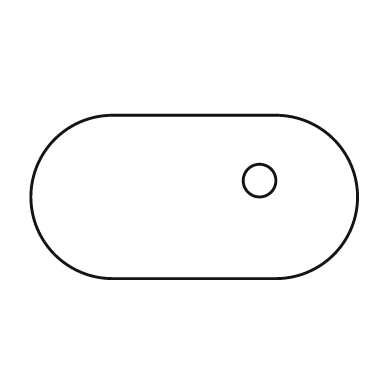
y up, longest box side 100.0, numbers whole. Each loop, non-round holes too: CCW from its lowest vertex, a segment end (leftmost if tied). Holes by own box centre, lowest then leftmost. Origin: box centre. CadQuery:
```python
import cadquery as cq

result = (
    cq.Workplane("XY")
    .moveTo(-25.0, -25.0)
    .lineTo(25.0, -25.0)
    .threePointArc((50.0, 0.0), (25.0, 25.0))
    .lineTo(-25.0, 25.0)
    .threePointArc((-50.0, 0.0), (-25.0, -25.0))
    .close()
    .moveTo(20.0, 5.0)
    .circle(5.0)
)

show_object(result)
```